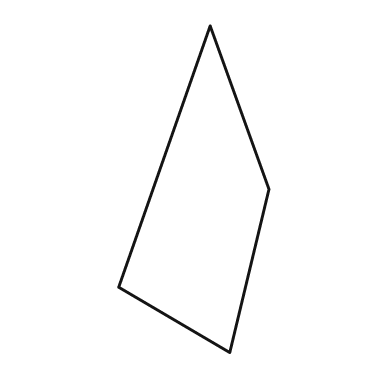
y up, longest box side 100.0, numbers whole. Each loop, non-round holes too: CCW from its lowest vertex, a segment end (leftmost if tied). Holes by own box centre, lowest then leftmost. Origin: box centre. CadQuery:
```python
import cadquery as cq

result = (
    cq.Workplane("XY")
    .moveTo(11.0, -50.0)
    .lineTo(23.0, 0.0)
    .lineTo(5.0, 50.0)
    .lineTo(-23.0, -30.0)
    .close()
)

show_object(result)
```